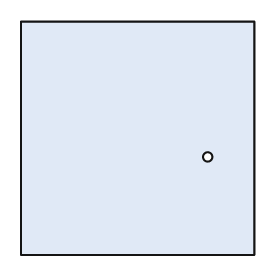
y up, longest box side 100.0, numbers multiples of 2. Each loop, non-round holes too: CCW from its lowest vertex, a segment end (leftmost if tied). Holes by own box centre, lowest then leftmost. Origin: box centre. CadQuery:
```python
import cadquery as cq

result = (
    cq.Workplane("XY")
    .moveTo(-50.0, -50.0)
    .lineTo(50.0, -50.0)
    .lineTo(50.0, 50.0)
    .lineTo(-50.0, 50.0)
    .close()
    .moveTo(30.0, -8.0)
    .circle(2.0)
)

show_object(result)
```